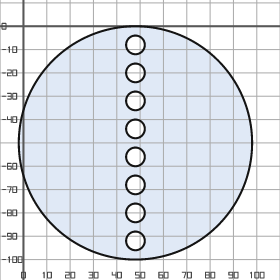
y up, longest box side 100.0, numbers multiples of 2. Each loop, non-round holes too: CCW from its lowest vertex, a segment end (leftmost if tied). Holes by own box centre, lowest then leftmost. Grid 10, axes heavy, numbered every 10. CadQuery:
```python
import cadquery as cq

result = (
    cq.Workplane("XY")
    .moveTo(48.0, -50.0)
    .circle(50.0)
    .moveTo(48.0, -92.0)
    .circle(4.0)
    .moveTo(48.0, -80.0)
    .circle(4.0)
    .moveTo(48.0, -68.0)
    .circle(4.0)
    .moveTo(48.0, -56.0)
    .circle(4.0)
    .moveTo(48.0, -44.0)
    .circle(4.0)
    .moveTo(48.0, -32.0)
    .circle(4.0)
    .moveTo(48.0, -20.0)
    .circle(4.0)
    .moveTo(48.0, -8.0)
    .circle(4.0)
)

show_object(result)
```